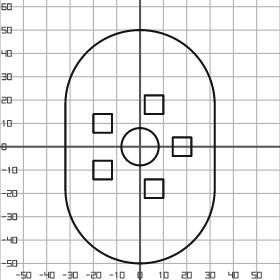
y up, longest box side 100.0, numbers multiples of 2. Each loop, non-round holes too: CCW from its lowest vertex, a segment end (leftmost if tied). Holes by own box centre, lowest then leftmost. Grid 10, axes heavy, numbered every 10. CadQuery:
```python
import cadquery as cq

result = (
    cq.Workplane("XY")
    .moveTo(-32.0, -18.0)
    .threePointArc((0.0, -50.0), (32.0, -18.0))
    .lineTo(32.0, 18.0)
    .threePointArc((0.0, 50.0), (-32.0, 18.0))
    .close()
    .moveTo(2.0, -22.0)
    .lineTo(10.0, -22.0)
    .lineTo(10.0, -14.0)
    .lineTo(2.0, -14.0)
    .close()
    .moveTo(-20.0, -14.0)
    .lineTo(-12.0, -14.0)
    .lineTo(-12.0, -6.0)
    .lineTo(-20.0, -6.0)
    .close()
    .moveTo(0.0, 0.0)
    .circle(8.0)
    .moveTo(14.0, -4.0)
    .lineTo(22.0, -4.0)
    .lineTo(22.0, 4.0)
    .lineTo(14.0, 4.0)
    .close()
    .moveTo(-20.0, 6.0)
    .lineTo(-12.0, 6.0)
    .lineTo(-12.0, 14.0)
    .lineTo(-20.0, 14.0)
    .close()
    .moveTo(2.0, 14.0)
    .lineTo(10.0, 14.0)
    .lineTo(10.0, 22.0)
    .lineTo(2.0, 22.0)
    .close()
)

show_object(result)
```